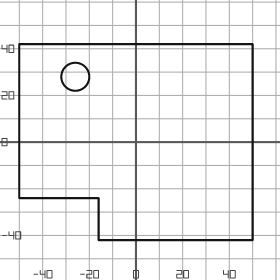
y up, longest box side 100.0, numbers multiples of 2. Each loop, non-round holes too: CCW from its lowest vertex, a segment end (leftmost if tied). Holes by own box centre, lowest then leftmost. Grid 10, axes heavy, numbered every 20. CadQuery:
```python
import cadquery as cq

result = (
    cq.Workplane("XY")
    .moveTo(-16.0, -42.0)
    .lineTo(50.0, -42.0)
    .lineTo(50.0, 42.0)
    .lineTo(-50.0, 42.0)
    .lineTo(-50.0, -24.0)
    .lineTo(-16.0, -24.0)
    .close()
    .moveTo(-26.0, 28.0)
    .circle(6.0)
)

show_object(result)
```